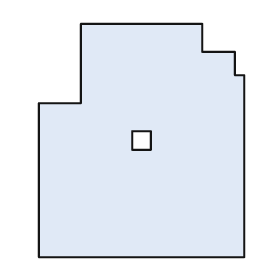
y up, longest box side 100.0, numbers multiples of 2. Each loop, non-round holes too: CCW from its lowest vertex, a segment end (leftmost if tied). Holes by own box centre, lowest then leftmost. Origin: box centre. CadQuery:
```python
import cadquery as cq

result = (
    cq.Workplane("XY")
    .moveTo(-44.0, -50.0)
    .lineTo(44.0, -50.0)
    .lineTo(44.0, 28.0)
    .lineTo(40.0, 28.0)
    .lineTo(40.0, 38.0)
    .lineTo(26.0, 38.0)
    .lineTo(26.0, 50.0)
    .lineTo(-26.0, 50.0)
    .lineTo(-26.0, 16.0)
    .lineTo(-44.0, 16.0)
    .close()
    .moveTo(-4.0, -4.0)
    .lineTo(4.0, -4.0)
    .lineTo(4.0, 4.0)
    .lineTo(-4.0, 4.0)
    .close()
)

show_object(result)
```